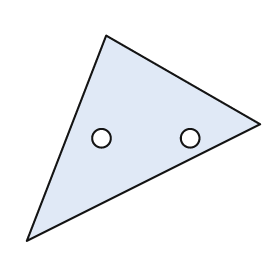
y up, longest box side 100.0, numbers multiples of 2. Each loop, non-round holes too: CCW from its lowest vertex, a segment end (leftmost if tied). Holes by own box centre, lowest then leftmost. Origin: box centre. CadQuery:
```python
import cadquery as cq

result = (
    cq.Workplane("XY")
    .moveTo(-50.0, -44.0)
    .lineTo(50.0, 6.0)
    .lineTo(-16.0, 44.0)
    .close()
    .moveTo(-18.0, 0.0)
    .circle(4.0)
    .moveTo(20.0, 0.0)
    .circle(4.0)
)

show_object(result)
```